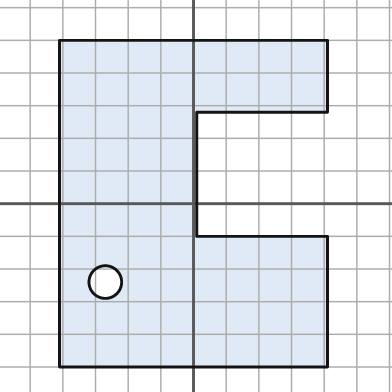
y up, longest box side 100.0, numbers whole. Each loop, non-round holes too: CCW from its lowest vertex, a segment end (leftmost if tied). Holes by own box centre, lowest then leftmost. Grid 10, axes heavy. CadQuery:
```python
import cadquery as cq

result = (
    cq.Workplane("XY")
    .moveTo(-41.0, -50.0)
    .lineTo(41.0, -50.0)
    .lineTo(41.0, -10.0)
    .lineTo(1.0, -10.0)
    .lineTo(1.0, 28.0)
    .lineTo(41.0, 28.0)
    .lineTo(41.0, 50.0)
    .lineTo(-41.0, 50.0)
    .close()
    .moveTo(-27.0, -24.0)
    .circle(5.0)
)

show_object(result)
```